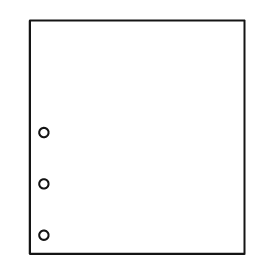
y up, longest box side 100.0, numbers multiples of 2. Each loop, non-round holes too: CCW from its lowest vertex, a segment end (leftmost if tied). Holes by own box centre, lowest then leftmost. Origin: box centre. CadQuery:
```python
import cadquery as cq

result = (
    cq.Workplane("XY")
    .moveTo(-46.0, -50.0)
    .lineTo(46.0, -50.0)
    .lineTo(46.0, 50.0)
    .lineTo(-46.0, 50.0)
    .close()
    .moveTo(-40.0, -42.0)
    .circle(2.0)
    .moveTo(-40.0, -20.0)
    .circle(2.0)
    .moveTo(-40.0, 2.0)
    .circle(2.0)
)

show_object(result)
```